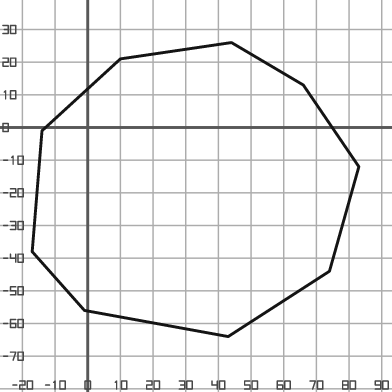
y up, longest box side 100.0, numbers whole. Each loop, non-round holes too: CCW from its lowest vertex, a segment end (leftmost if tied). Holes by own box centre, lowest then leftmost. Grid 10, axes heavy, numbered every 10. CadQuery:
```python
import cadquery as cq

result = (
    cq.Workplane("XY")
    .moveTo(43.0, -64.0)
    .lineTo(74.0, -44.0)
    .lineTo(83.0, -12.0)
    .lineTo(66.0, 13.0)
    .lineTo(44.0, 26.0)
    .lineTo(10.0, 21.0)
    .lineTo(-14.0, -1.0)
    .lineTo(-17.0, -38.0)
    .lineTo(-1.0, -56.0)
    .close()
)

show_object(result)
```